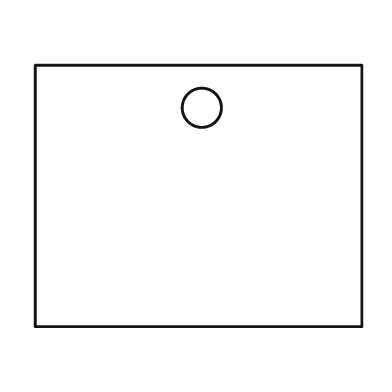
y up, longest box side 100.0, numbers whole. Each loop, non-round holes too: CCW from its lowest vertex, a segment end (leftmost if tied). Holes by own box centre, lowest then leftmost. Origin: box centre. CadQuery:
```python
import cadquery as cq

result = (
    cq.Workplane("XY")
    .moveTo(-50.0, -40.0)
    .lineTo(50.0, -40.0)
    .lineTo(50.0, 40.0)
    .lineTo(-50.0, 40.0)
    .close()
    .moveTo(1.0, 27.0)
    .circle(6.0)
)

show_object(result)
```